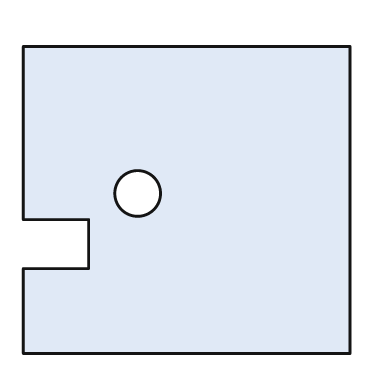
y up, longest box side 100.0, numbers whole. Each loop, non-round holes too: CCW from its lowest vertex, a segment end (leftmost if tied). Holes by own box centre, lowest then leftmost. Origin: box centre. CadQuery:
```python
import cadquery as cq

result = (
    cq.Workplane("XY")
    .moveTo(-50.0, -47.0)
    .lineTo(50.0, -47.0)
    .lineTo(50.0, 47.0)
    .lineTo(-50.0, 47.0)
    .lineTo(-50.0, -6.0)
    .lineTo(-30.0, -6.0)
    .lineTo(-30.0, -21.0)
    .lineTo(-50.0, -21.0)
    .close()
    .moveTo(-15.0, 2.0)
    .circle(7.0)
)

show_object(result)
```